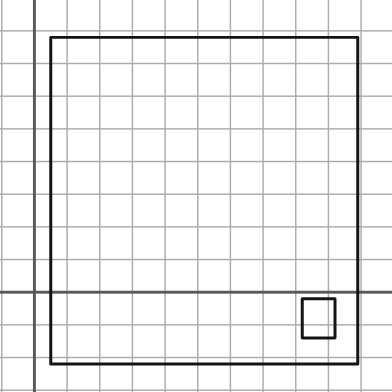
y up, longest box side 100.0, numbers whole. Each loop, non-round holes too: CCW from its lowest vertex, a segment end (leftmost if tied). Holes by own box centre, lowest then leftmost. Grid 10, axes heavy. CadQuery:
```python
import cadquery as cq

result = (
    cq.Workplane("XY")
    .moveTo(5.0, -22.0)
    .lineTo(99.0, -22.0)
    .lineTo(99.0, 78.0)
    .lineTo(5.0, 78.0)
    .close()
    .moveTo(82.0, -14.0)
    .lineTo(92.0, -14.0)
    .lineTo(92.0, -2.0)
    .lineTo(82.0, -2.0)
    .close()
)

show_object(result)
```